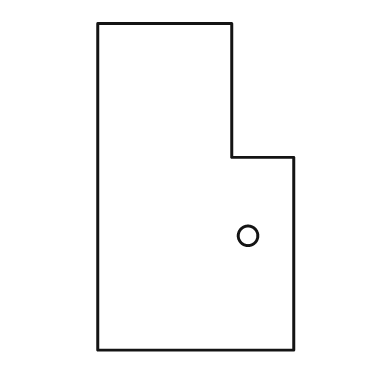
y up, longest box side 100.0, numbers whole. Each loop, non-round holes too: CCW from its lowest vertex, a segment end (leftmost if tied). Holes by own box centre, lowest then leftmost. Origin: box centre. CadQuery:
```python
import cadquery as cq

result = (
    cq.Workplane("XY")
    .moveTo(-30.0, -50.0)
    .lineTo(30.0, -50.0)
    .lineTo(30.0, 9.0)
    .lineTo(11.0, 9.0)
    .lineTo(11.0, 50.0)
    .lineTo(-30.0, 50.0)
    .close()
    .moveTo(16.0, -15.0)
    .circle(3.0)
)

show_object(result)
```